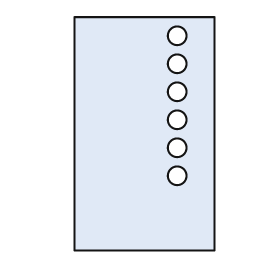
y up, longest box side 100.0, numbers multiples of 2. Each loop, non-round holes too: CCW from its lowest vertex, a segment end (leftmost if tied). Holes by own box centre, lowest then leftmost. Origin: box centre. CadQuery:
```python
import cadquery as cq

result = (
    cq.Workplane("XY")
    .moveTo(-30.0, -50.0)
    .lineTo(30.0, -50.0)
    .lineTo(30.0, 50.0)
    .lineTo(-30.0, 50.0)
    .close()
    .moveTo(14.0, -18.0)
    .circle(4.0)
    .moveTo(14.0, -6.0)
    .circle(4.0)
    .moveTo(14.0, 6.0)
    .circle(4.0)
    .moveTo(14.0, 18.0)
    .circle(4.0)
    .moveTo(14.0, 30.0)
    .circle(4.0)
    .moveTo(14.0, 42.0)
    .circle(4.0)
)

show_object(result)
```